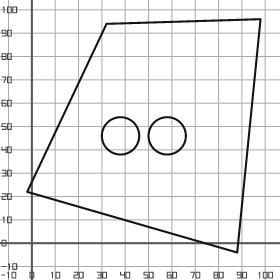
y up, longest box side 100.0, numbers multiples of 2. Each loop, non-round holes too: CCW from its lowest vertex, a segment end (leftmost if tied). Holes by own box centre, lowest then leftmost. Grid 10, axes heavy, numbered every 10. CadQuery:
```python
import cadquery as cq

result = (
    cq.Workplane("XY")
    .moveTo(88.0, -4.0)
    .lineTo(98.0, 96.0)
    .lineTo(32.0, 94.0)
    .lineTo(-2.0, 22.0)
    .close()
    .moveTo(38.0, 46.0)
    .circle(8.0)
    .moveTo(58.0, 46.0)
    .circle(8.0)
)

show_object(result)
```